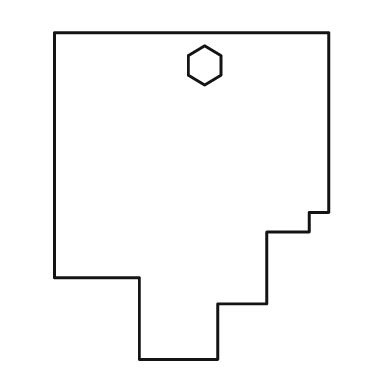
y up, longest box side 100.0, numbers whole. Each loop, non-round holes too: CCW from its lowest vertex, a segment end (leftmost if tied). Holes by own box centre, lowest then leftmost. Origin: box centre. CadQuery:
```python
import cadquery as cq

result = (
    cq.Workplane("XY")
    .moveTo(-16.0, -50.0)
    .lineTo(8.0, -50.0)
    .lineTo(8.0, -33.0)
    .lineTo(23.0, -33.0)
    .lineTo(23.0, -11.0)
    .lineTo(36.0, -11.0)
    .lineTo(36.0, -5.0)
    .lineTo(42.0, -5.0)
    .lineTo(42.0, 50.0)
    .lineTo(-42.0, 50.0)
    .lineTo(-42.0, -25.0)
    .lineTo(-16.0, -25.0)
    .close()
    .moveTo(4.0, 34.0)
    .lineTo(9.0, 37.0)
    .lineTo(9.0, 43.0)
    .lineTo(4.0, 46.0)
    .lineTo(-1.0, 43.0)
    .lineTo(-1.0, 37.0)
    .close()
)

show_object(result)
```